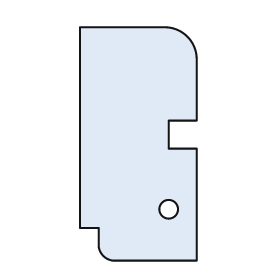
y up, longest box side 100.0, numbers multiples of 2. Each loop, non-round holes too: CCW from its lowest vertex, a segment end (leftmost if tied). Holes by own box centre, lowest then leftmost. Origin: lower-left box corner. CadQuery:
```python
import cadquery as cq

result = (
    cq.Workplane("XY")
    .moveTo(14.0, 0.0)
    .lineTo(50.0, 0.0)
    .lineTo(50.0, 48.0)
    .lineTo(38.0, 48.0)
    .lineTo(38.0, 60.0)
    .lineTo(50.0, 60.0)
    .lineTo(50.0, 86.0)
    .threePointArc((46.0, 96.0), (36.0, 100.0))
    .lineTo(0.0, 100.0)
    .lineTo(0.0, 14.0)
    .lineTo(8.0, 14.0)
    .lineTo(8.0, 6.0)
    .threePointArc((10.0, 2.0), (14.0, 0.0))
    .close()
    .moveTo(38.0, 22.0)
    .circle(4.0)
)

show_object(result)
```